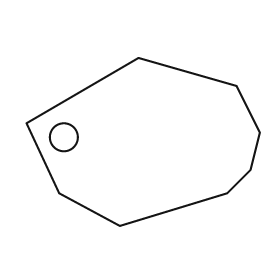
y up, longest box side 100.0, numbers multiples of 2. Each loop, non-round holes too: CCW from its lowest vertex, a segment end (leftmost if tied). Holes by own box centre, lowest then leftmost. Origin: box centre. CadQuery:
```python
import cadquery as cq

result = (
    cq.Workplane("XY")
    .moveTo(-10.0, -36.0)
    .lineTo(36.0, -22.0)
    .lineTo(46.0, -12.0)
    .lineTo(50.0, 4.0)
    .lineTo(40.0, 24.0)
    .lineTo(-2.0, 36.0)
    .lineTo(-50.0, 8.0)
    .lineTo(-36.0, -22.0)
    .close()
    .moveTo(-34.0, 2.0)
    .circle(6.0)
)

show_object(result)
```